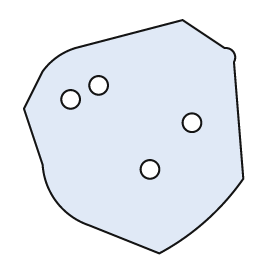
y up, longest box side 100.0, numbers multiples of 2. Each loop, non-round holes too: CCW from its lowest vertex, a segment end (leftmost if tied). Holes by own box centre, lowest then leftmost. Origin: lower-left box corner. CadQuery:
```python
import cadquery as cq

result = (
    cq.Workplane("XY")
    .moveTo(58.0, 0.0)
    .threePointArc((78.0, 14.0), (94.0, 32.0))
    .lineTo(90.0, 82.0)
    .threePointArc((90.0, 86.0), (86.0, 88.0))
    .lineTo(68.0, 100.0)
    .lineTo(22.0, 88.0)
    .threePointArc((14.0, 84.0), (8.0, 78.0))
    .lineTo(0.0, 62.0)
    .lineTo(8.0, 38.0)
    .threePointArc((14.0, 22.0), (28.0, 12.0))
    .close()
    .moveTo(54.0, 36.0)
    .circle(4.0)
    .moveTo(72.0, 56.0)
    .circle(4.0)
    .moveTo(20.0, 66.0)
    .circle(4.0)
    .moveTo(32.0, 72.0)
    .circle(4.0)
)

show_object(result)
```